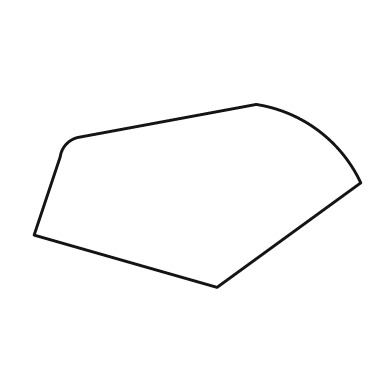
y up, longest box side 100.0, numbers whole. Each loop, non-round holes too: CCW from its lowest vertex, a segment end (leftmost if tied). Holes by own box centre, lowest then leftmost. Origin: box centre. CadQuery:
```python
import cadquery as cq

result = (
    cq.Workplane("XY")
    .moveTo(6.0, -28.0)
    .lineTo(50.0, 4.0)
    .threePointArc((37.0, 20.0), (18.0, 28.0))
    .lineTo(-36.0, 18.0)
    .threePointArc((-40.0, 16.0), (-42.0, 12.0))
    .lineTo(-50.0, -12.0)
    .close()
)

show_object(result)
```